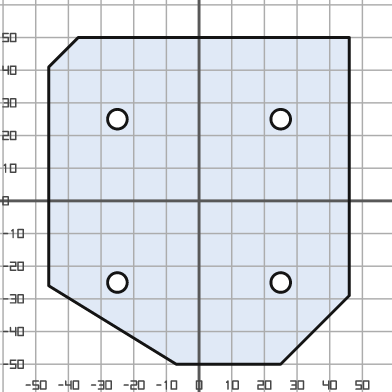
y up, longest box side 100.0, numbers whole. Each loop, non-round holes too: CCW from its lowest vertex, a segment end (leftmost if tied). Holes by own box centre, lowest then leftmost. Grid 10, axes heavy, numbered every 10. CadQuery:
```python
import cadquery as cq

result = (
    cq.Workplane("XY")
    .moveTo(-7.0, -50.0)
    .lineTo(25.0, -50.0)
    .lineTo(46.0, -29.0)
    .lineTo(46.0, 50.0)
    .lineTo(-37.0, 50.0)
    .lineTo(-46.0, 41.0)
    .lineTo(-46.0, -26.0)
    .close()
    .moveTo(-25.0, -25.0)
    .circle(3.0)
    .moveTo(25.0, -25.0)
    .circle(3.0)
    .moveTo(-25.0, 25.0)
    .circle(3.0)
    .moveTo(25.0, 25.0)
    .circle(3.0)
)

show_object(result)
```